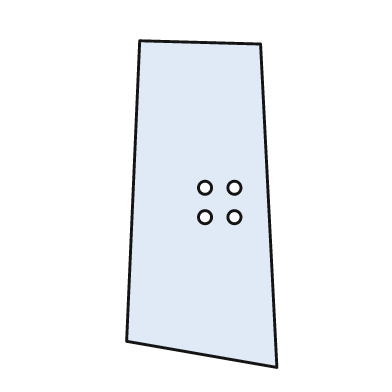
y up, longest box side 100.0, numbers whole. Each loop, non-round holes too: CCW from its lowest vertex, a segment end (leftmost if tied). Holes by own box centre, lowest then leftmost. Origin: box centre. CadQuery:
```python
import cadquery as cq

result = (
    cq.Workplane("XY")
    .moveTo(23.0, -50.0)
    .lineTo(18.0, 49.0)
    .lineTo(-19.0, 50.0)
    .lineTo(-23.0, -42.0)
    .close()
    .moveTo(1.0, -4.0)
    .circle(2.0)
    .moveTo(10.0, -4.0)
    .circle(2.0)
    .moveTo(1.0, 5.0)
    .circle(2.0)
    .moveTo(10.0, 5.0)
    .circle(2.0)
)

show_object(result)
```